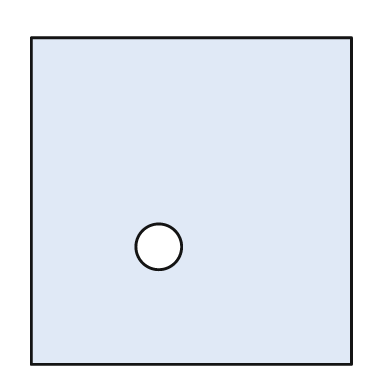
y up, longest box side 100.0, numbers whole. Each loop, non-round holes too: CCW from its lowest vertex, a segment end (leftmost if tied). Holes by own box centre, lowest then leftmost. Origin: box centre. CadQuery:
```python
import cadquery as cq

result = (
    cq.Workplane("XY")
    .moveTo(-49.0, -50.0)
    .lineTo(49.0, -50.0)
    .lineTo(49.0, 50.0)
    .lineTo(-49.0, 50.0)
    .close()
    .moveTo(-10.0, -14.0)
    .circle(7.0)
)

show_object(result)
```